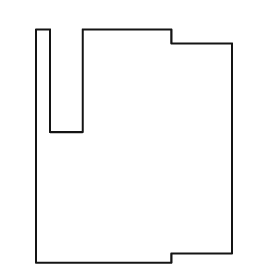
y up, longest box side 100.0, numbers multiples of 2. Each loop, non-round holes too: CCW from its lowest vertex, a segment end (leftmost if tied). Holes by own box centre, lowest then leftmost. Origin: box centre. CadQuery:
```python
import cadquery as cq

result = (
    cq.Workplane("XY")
    .moveTo(-42.0, -50.0)
    .lineTo(16.0, -50.0)
    .lineTo(16.0, -46.0)
    .lineTo(42.0, -46.0)
    .lineTo(42.0, 44.0)
    .lineTo(16.0, 44.0)
    .lineTo(16.0, 50.0)
    .lineTo(-22.0, 50.0)
    .lineTo(-22.0, 6.0)
    .lineTo(-36.0, 6.0)
    .lineTo(-36.0, 50.0)
    .lineTo(-42.0, 50.0)
    .close()
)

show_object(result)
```